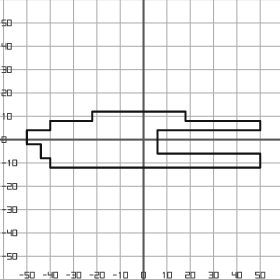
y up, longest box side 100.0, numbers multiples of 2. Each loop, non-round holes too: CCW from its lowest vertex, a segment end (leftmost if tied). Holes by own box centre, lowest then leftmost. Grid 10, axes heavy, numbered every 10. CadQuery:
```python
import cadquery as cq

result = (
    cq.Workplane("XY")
    .moveTo(-40.0, -12.0)
    .lineTo(50.0, -12.0)
    .lineTo(50.0, -6.0)
    .lineTo(6.0, -6.0)
    .lineTo(6.0, 4.0)
    .lineTo(50.0, 4.0)
    .lineTo(50.0, 8.0)
    .lineTo(18.0, 8.0)
    .lineTo(18.0, 12.0)
    .lineTo(-22.0, 12.0)
    .lineTo(-22.0, 8.0)
    .lineTo(-40.0, 8.0)
    .lineTo(-40.0, 4.0)
    .lineTo(-50.0, 4.0)
    .lineTo(-50.0, -2.0)
    .lineTo(-44.0, -2.0)
    .lineTo(-44.0, -8.0)
    .lineTo(-40.0, -8.0)
    .close()
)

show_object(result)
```